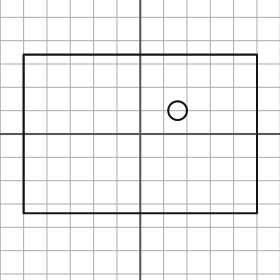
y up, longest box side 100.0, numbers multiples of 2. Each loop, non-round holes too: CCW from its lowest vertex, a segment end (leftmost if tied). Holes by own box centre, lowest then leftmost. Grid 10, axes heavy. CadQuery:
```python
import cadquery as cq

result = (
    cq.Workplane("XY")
    .moveTo(-50.0, -34.0)
    .lineTo(50.0, -34.0)
    .lineTo(50.0, 34.0)
    .lineTo(-50.0, 34.0)
    .close()
    .moveTo(16.0, 10.0)
    .circle(4.0)
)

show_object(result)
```